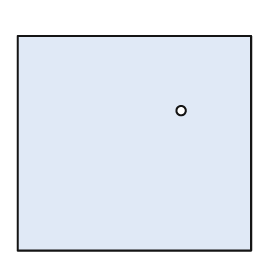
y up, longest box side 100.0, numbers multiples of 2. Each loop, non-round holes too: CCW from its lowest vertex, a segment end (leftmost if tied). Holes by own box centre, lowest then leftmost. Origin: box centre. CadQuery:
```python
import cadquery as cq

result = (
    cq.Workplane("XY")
    .moveTo(-50.0, -46.0)
    .lineTo(50.0, -46.0)
    .lineTo(50.0, 46.0)
    .lineTo(-50.0, 46.0)
    .close()
    .moveTo(20.0, 14.0)
    .circle(2.0)
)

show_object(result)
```